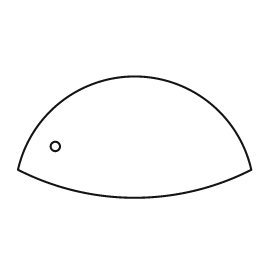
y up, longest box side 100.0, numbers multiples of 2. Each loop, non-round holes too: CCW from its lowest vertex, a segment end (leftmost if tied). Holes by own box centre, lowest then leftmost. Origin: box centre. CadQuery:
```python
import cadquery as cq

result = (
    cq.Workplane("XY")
    .moveTo(-50.0, -14.0)
    .threePointArc((0.0, -26.0), (50.0, -14.0))
    .threePointArc((0.0, 26.0), (-50.0, -14.0))
    .close()
    .moveTo(-34.0, -4.0)
    .circle(2.0)
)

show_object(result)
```